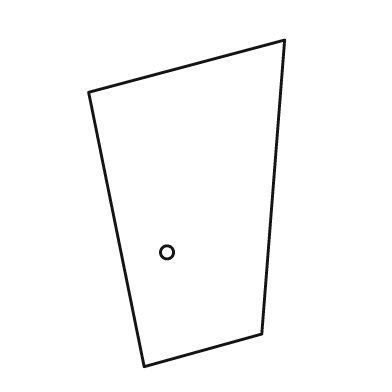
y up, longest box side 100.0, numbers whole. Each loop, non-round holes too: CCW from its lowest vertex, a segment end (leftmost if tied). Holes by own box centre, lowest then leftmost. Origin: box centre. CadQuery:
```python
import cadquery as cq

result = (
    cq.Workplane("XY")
    .moveTo(-13.0, -50.0)
    .lineTo(23.0, -40.0)
    .lineTo(30.0, 50.0)
    .lineTo(-30.0, 34.0)
    .close()
    .moveTo(-6.0, -15.0)
    .circle(2.0)
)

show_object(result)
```